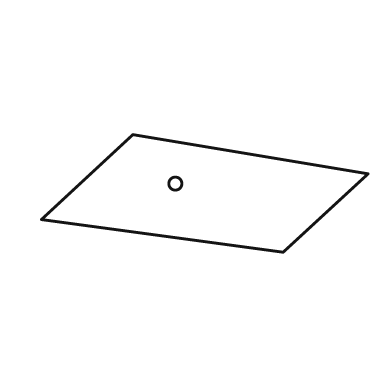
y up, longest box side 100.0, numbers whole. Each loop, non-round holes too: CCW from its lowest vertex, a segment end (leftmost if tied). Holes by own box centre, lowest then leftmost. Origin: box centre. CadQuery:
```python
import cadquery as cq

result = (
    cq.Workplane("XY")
    .moveTo(24.0, -18.0)
    .lineTo(50.0, 6.0)
    .lineTo(-22.0, 18.0)
    .lineTo(-50.0, -8.0)
    .close()
    .moveTo(-9.0, 3.0)
    .circle(2.0)
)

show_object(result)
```